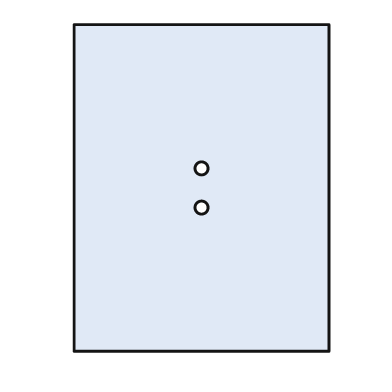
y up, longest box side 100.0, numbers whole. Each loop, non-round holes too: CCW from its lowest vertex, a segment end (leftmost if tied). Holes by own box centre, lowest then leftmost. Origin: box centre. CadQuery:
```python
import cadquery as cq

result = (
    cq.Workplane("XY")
    .moveTo(-39.0, -50.0)
    .lineTo(39.0, -50.0)
    .lineTo(39.0, 50.0)
    .lineTo(-39.0, 50.0)
    .close()
    .moveTo(0.0, -6.0)
    .circle(2.0)
    .moveTo(0.0, 6.0)
    .circle(2.0)
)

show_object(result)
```